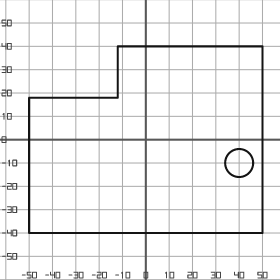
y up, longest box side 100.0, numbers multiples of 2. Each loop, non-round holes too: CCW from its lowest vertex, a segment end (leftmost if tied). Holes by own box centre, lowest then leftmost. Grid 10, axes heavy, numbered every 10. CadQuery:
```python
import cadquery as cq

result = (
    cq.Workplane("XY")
    .moveTo(-50.0, -40.0)
    .lineTo(50.0, -40.0)
    .lineTo(50.0, 40.0)
    .lineTo(-12.0, 40.0)
    .lineTo(-12.0, 18.0)
    .lineTo(-50.0, 18.0)
    .close()
    .moveTo(40.0, -10.0)
    .circle(6.0)
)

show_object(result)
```